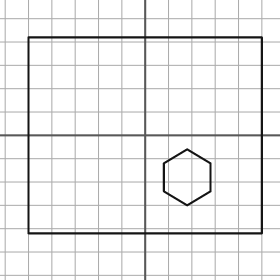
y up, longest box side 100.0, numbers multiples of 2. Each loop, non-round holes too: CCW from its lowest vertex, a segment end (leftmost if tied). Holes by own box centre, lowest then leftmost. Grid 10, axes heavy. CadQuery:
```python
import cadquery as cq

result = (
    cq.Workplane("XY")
    .moveTo(-50.0, -42.0)
    .lineTo(50.0, -42.0)
    .lineTo(50.0, 42.0)
    .lineTo(-50.0, 42.0)
    .close()
    .moveTo(18.0, -30.0)
    .lineTo(28.0, -24.0)
    .lineTo(28.0, -12.0)
    .lineTo(18.0, -6.0)
    .lineTo(8.0, -12.0)
    .lineTo(8.0, -24.0)
    .close()
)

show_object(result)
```